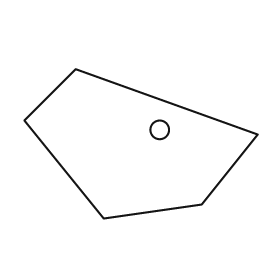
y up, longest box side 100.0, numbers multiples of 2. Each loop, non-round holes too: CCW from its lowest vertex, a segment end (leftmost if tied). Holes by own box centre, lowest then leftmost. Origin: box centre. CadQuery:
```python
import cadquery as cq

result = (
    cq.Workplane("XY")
    .moveTo(-16.0, -32.0)
    .lineTo(26.0, -26.0)
    .lineTo(50.0, 4.0)
    .lineTo(-28.0, 32.0)
    .lineTo(-50.0, 10.0)
    .close()
    .moveTo(8.0, 6.0)
    .circle(4.0)
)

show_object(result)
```